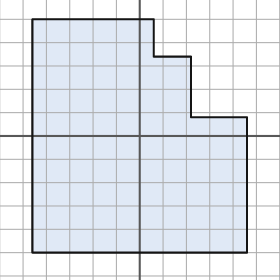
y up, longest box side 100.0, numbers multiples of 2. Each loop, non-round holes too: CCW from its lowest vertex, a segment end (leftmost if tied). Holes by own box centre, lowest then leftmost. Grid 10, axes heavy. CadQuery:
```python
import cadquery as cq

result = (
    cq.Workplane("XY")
    .moveTo(-46.0, -50.0)
    .lineTo(46.0, -50.0)
    .lineTo(46.0, 8.0)
    .lineTo(22.0, 8.0)
    .lineTo(22.0, 34.0)
    .lineTo(6.0, 34.0)
    .lineTo(6.0, 50.0)
    .lineTo(-46.0, 50.0)
    .close()
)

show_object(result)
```